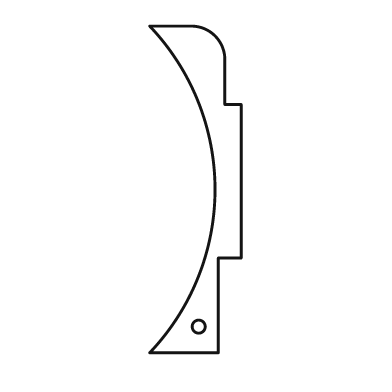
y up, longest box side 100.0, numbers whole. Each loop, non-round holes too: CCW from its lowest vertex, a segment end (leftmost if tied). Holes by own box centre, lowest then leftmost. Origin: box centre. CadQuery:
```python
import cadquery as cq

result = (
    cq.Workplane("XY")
    .moveTo(-14.0, -50.0)
    .lineTo(7.0, -50.0)
    .lineTo(7.0, -21.0)
    .lineTo(14.0, -21.0)
    .lineTo(14.0, 26.0)
    .lineTo(9.0, 26.0)
    .lineTo(9.0, 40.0)
    .threePointArc((6.0, 47.0), (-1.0, 50.0))
    .lineTo(-14.0, 50.0)
    .threePointArc((6.0, 0.0), (-14.0, -50.0))
    .close()
    .moveTo(1.0, -42.0)
    .circle(2.0)
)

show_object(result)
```